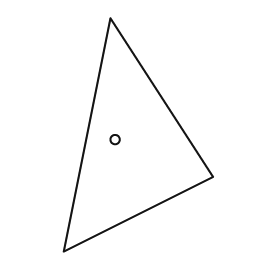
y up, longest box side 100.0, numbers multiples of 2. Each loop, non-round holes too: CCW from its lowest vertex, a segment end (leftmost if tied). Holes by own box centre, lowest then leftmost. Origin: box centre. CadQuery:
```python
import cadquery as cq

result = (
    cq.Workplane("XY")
    .moveTo(-32.0, -50.0)
    .lineTo(32.0, -18.0)
    .lineTo(-12.0, 50.0)
    .close()
    .moveTo(-10.0, -2.0)
    .circle(2.0)
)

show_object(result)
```